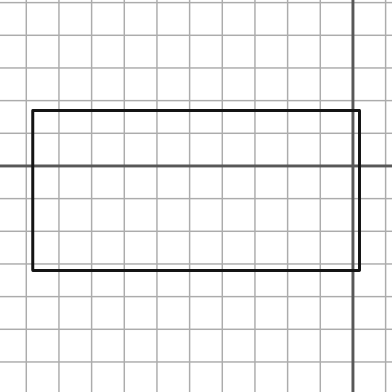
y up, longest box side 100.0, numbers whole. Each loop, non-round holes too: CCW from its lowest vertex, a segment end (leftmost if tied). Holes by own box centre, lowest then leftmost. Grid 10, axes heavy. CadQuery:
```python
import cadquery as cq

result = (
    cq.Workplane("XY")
    .moveTo(-98.0, -32.0)
    .lineTo(2.0, -32.0)
    .lineTo(2.0, 17.0)
    .lineTo(-98.0, 17.0)
    .close()
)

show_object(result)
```